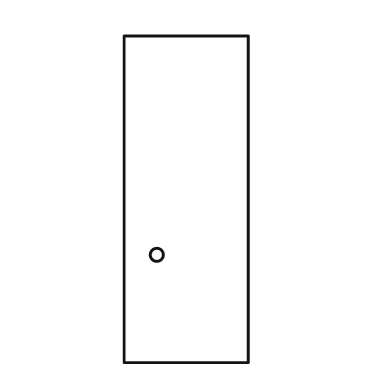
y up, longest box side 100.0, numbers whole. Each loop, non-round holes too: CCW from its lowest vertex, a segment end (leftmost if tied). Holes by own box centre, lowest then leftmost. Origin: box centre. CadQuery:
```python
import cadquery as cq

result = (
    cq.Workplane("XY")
    .moveTo(-19.0, -50.0)
    .lineTo(19.0, -50.0)
    .lineTo(19.0, 50.0)
    .lineTo(-19.0, 50.0)
    .close()
    .moveTo(-9.0, -17.0)
    .circle(2.0)
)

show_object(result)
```